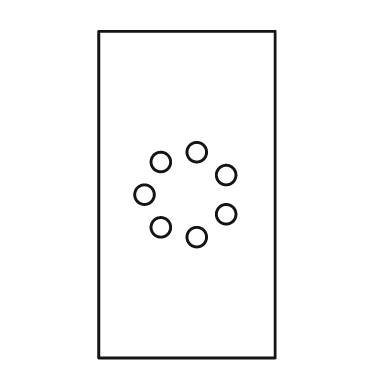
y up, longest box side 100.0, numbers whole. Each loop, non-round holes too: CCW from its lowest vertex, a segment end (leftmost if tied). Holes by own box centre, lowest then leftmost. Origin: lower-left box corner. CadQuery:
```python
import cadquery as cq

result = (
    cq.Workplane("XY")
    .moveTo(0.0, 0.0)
    .lineTo(54.0, 0.0)
    .lineTo(54.0, 100.0)
    .lineTo(0.0, 100.0)
    .close()
    .moveTo(30.0, 37.0)
    .circle(3.0)
    .moveTo(19.0, 40.0)
    .circle(3.0)
    .moveTo(39.0, 44.0)
    .circle(3.0)
    .moveTo(14.0, 50.0)
    .circle(3.0)
    .moveTo(39.0, 56.0)
    .circle(3.0)
    .moveTo(19.0, 60.0)
    .circle(3.0)
    .moveTo(30.0, 63.0)
    .circle(3.0)
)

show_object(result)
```